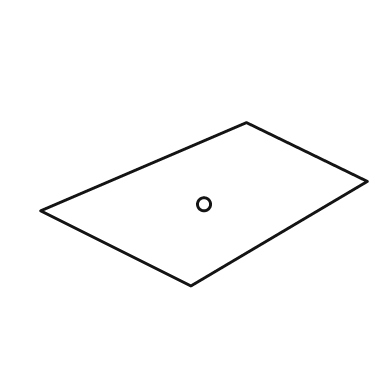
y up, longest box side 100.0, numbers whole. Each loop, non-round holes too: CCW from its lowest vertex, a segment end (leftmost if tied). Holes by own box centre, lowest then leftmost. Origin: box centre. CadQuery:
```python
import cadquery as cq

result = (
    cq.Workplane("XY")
    .moveTo(-4.0, -25.0)
    .lineTo(50.0, 7.0)
    .lineTo(13.0, 25.0)
    .lineTo(-50.0, -2.0)
    .close()
    .moveTo(0.0, 0.0)
    .circle(2.0)
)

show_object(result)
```